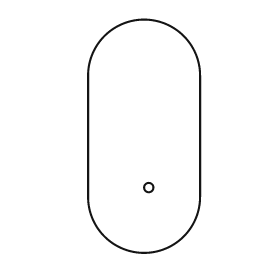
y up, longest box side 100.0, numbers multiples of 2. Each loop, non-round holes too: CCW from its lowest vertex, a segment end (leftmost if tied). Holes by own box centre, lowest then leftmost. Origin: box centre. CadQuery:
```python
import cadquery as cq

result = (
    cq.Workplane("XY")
    .moveTo(-24.0, -26.0)
    .threePointArc((0.0, -50.0), (24.0, -26.0))
    .lineTo(24.0, 26.0)
    .threePointArc((0.0, 50.0), (-24.0, 26.0))
    .close()
    .moveTo(2.0, -22.0)
    .circle(2.0)
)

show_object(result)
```